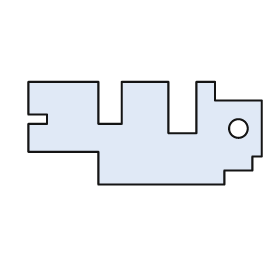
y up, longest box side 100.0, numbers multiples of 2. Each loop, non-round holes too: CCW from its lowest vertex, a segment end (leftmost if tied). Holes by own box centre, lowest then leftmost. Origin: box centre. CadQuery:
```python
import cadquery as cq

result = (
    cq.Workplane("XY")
    .moveTo(-20.0, -22.0)
    .lineTo(34.0, -22.0)
    .lineTo(34.0, -16.0)
    .lineTo(46.0, -16.0)
    .lineTo(46.0, -10.0)
    .lineTo(50.0, -10.0)
    .lineTo(50.0, 14.0)
    .lineTo(30.0, 14.0)
    .lineTo(30.0, 22.0)
    .lineTo(22.0, 22.0)
    .lineTo(22.0, 0.0)
    .lineTo(10.0, 0.0)
    .lineTo(10.0, 22.0)
    .lineTo(-10.0, 22.0)
    .lineTo(-10.0, 4.0)
    .lineTo(-20.0, 4.0)
    .lineTo(-20.0, 22.0)
    .lineTo(-50.0, 22.0)
    .lineTo(-50.0, 8.0)
    .lineTo(-42.0, 8.0)
    .lineTo(-42.0, 4.0)
    .lineTo(-50.0, 4.0)
    .lineTo(-50.0, -8.0)
    .lineTo(-20.0, -8.0)
    .close()
    .moveTo(40.0, 2.0)
    .circle(4.0)
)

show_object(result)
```